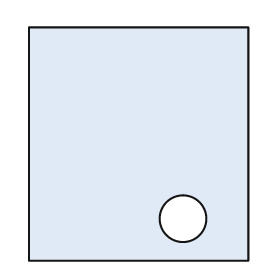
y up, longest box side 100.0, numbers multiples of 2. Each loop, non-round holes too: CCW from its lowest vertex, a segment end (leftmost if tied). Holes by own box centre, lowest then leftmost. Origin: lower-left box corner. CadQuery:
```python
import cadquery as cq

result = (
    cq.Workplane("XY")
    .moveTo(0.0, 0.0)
    .lineTo(94.0, 0.0)
    .lineTo(94.0, 100.0)
    .lineTo(0.0, 100.0)
    .close()
    .moveTo(66.0, 18.0)
    .circle(10.0)
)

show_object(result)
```